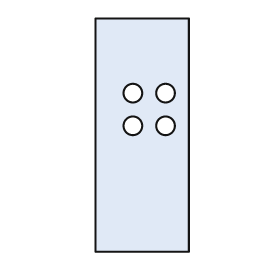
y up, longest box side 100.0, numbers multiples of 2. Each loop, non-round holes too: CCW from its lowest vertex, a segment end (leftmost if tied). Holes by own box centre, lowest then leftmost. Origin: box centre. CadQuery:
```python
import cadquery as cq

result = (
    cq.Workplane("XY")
    .moveTo(-20.0, -50.0)
    .lineTo(20.0, -50.0)
    .lineTo(20.0, 50.0)
    .lineTo(-20.0, 50.0)
    .close()
    .moveTo(-4.0, 4.0)
    .circle(4.0)
    .moveTo(10.0, 4.0)
    .circle(4.0)
    .moveTo(-4.0, 18.0)
    .circle(4.0)
    .moveTo(10.0, 18.0)
    .circle(4.0)
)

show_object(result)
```